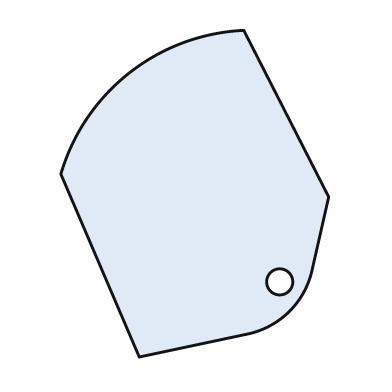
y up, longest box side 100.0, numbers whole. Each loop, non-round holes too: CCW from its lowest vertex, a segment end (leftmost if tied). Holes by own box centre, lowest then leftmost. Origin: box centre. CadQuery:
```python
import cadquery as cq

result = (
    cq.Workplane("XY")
    .moveTo(-17.0, -50.0)
    .lineTo(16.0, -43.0)
    .threePointArc((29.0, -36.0), (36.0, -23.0))
    .lineTo(41.0, -1.0)
    .lineTo(15.0, 50.0)
    .threePointArc((-20.0, 37.0), (-41.0, 6.0))
    .close()
    .moveTo(26.0, -27.0)
    .circle(4.0)
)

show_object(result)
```